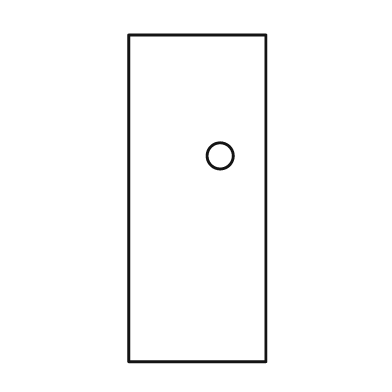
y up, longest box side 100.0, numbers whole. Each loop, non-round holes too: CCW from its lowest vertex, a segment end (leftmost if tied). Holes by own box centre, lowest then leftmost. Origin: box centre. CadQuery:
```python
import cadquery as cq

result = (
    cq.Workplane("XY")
    .moveTo(-21.0, -50.0)
    .lineTo(21.0, -50.0)
    .lineTo(21.0, 50.0)
    .lineTo(-21.0, 50.0)
    .close()
    .moveTo(7.0, 13.0)
    .circle(4.0)
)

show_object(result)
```